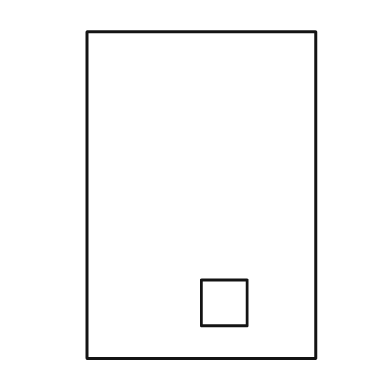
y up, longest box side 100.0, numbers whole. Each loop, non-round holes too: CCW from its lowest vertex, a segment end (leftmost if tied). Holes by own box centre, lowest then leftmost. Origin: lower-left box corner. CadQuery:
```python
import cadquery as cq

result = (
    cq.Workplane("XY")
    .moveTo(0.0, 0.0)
    .lineTo(70.0, 0.0)
    .lineTo(70.0, 100.0)
    .lineTo(0.0, 100.0)
    .close()
    .moveTo(35.0, 10.0)
    .lineTo(49.0, 10.0)
    .lineTo(49.0, 24.0)
    .lineTo(35.0, 24.0)
    .close()
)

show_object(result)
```